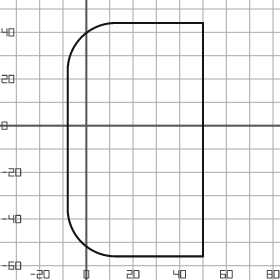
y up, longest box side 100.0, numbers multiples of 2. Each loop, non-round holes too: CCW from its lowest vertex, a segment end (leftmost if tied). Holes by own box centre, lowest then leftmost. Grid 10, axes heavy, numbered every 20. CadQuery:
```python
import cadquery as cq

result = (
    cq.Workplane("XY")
    .moveTo(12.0, -56.0)
    .lineTo(50.0, -56.0)
    .lineTo(50.0, 44.0)
    .lineTo(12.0, 44.0)
    .threePointArc((-2.0, 38.0), (-8.0, 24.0))
    .lineTo(-8.0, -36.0)
    .threePointArc((-2.0, -50.0), (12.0, -56.0))
    .close()
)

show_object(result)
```